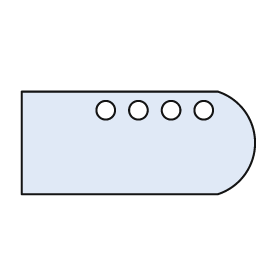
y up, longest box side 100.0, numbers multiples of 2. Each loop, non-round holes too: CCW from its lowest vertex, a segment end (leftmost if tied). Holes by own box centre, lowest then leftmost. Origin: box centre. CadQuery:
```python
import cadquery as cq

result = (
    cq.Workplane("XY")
    .moveTo(-50.0, -22.0)
    .lineTo(34.0, -22.0)
    .threePointArc((50.0, 0.0), (34.0, 22.0))
    .lineTo(-50.0, 22.0)
    .close()
    .moveTo(-14.0, 14.0)
    .circle(4.0)
    .moveTo(0.0, 14.0)
    .circle(4.0)
    .moveTo(14.0, 14.0)
    .circle(4.0)
    .moveTo(28.0, 14.0)
    .circle(4.0)
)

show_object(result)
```